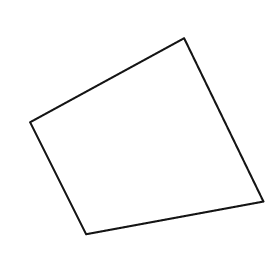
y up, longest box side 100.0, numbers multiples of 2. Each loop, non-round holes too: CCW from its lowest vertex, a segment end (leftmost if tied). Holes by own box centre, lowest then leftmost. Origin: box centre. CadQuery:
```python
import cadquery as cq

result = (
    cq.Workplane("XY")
    .moveTo(-26.0, -42.0)
    .lineTo(50.0, -28.0)
    .lineTo(16.0, 42.0)
    .lineTo(-50.0, 6.0)
    .close()
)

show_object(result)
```